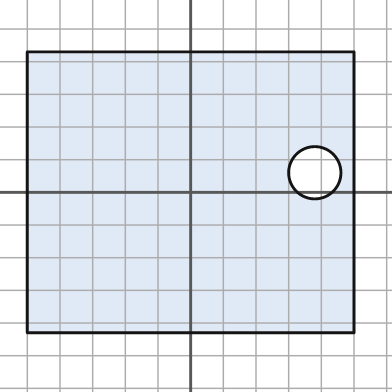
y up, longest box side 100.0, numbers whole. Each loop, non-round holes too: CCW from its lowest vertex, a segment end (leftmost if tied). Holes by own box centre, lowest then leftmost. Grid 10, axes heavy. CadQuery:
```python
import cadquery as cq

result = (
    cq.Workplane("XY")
    .moveTo(-50.0, -43.0)
    .lineTo(50.0, -43.0)
    .lineTo(50.0, 43.0)
    .lineTo(-50.0, 43.0)
    .close()
    .moveTo(38.0, 6.0)
    .circle(8.0)
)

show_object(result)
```